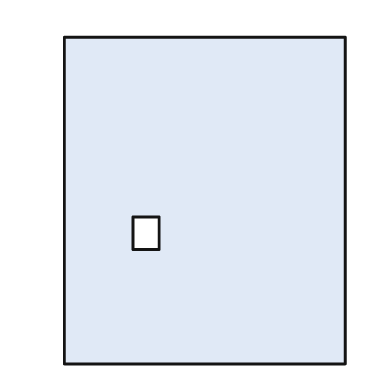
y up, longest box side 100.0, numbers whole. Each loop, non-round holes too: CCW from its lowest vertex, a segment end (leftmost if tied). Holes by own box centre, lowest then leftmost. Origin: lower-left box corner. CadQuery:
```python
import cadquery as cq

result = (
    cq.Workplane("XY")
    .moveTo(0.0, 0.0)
    .lineTo(86.0, 0.0)
    .lineTo(86.0, 100.0)
    .lineTo(0.0, 100.0)
    .close()
    .moveTo(21.0, 35.0)
    .lineTo(29.0, 35.0)
    .lineTo(29.0, 45.0)
    .lineTo(21.0, 45.0)
    .close()
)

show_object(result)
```